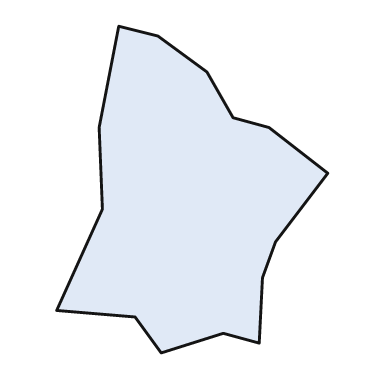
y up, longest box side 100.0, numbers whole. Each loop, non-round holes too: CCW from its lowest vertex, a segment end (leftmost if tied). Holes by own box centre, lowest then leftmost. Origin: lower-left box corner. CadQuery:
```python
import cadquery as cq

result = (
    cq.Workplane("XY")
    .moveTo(32.0, 0.0)
    .lineTo(51.0, 6.0)
    .lineTo(62.0, 3.0)
    .lineTo(63.0, 23.0)
    .lineTo(67.0, 34.0)
    .lineTo(83.0, 55.0)
    .lineTo(65.0, 69.0)
    .lineTo(54.0, 72.0)
    .lineTo(46.0, 86.0)
    .lineTo(31.0, 97.0)
    .lineTo(19.0, 100.0)
    .lineTo(13.0, 69.0)
    .lineTo(14.0, 44.0)
    .lineTo(0.0, 13.0)
    .lineTo(24.0, 11.0)
    .close()
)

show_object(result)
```